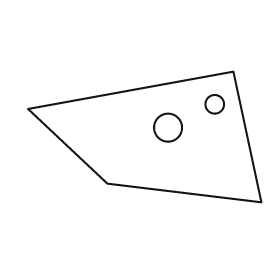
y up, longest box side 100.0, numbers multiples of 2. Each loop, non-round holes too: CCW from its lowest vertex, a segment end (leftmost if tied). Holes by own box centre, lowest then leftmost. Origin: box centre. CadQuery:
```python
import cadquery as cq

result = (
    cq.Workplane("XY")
    .moveTo(50.0, -28.0)
    .lineTo(38.0, 28.0)
    .lineTo(-50.0, 12.0)
    .lineTo(-16.0, -20.0)
    .close()
    .moveTo(10.0, 4.0)
    .circle(6.0)
    .moveTo(30.0, 14.0)
    .circle(4.0)
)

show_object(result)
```